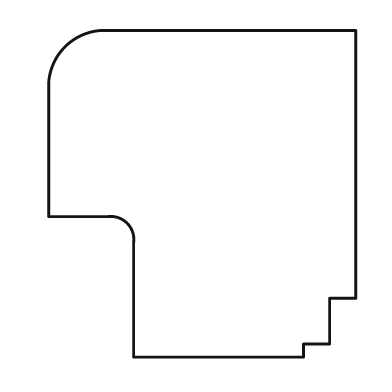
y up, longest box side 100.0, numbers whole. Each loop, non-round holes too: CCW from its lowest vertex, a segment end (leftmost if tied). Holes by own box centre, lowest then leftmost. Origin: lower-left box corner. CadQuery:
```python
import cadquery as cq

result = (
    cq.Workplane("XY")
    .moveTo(26.0, 0.0)
    .lineTo(78.0, 0.0)
    .lineTo(78.0, 4.0)
    .lineTo(86.0, 4.0)
    .lineTo(86.0, 18.0)
    .lineTo(94.0, 18.0)
    .lineTo(94.0, 100.0)
    .lineTo(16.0, 100.0)
    .threePointArc((5.0, 95.0), (0.0, 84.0))
    .lineTo(0.0, 43.0)
    .lineTo(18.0, 43.0)
    .threePointArc((24.0, 41.0), (26.0, 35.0))
    .close()
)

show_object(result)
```